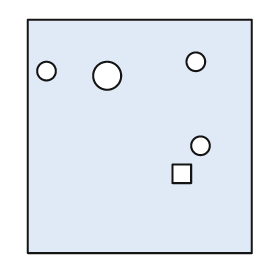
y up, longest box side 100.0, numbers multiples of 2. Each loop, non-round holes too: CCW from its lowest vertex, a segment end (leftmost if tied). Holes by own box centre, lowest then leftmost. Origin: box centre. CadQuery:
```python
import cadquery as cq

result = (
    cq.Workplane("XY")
    .moveTo(-48.0, -50.0)
    .lineTo(48.0, -50.0)
    .lineTo(48.0, 50.0)
    .lineTo(-48.0, 50.0)
    .close()
    .moveTo(14.0, -20.0)
    .lineTo(22.0, -20.0)
    .lineTo(22.0, -12.0)
    .lineTo(14.0, -12.0)
    .close()
    .moveTo(26.0, -4.0)
    .circle(4.0)
    .moveTo(-14.0, 26.0)
    .circle(6.0)
    .moveTo(-40.0, 28.0)
    .circle(4.0)
    .moveTo(24.0, 32.0)
    .circle(4.0)
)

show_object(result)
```